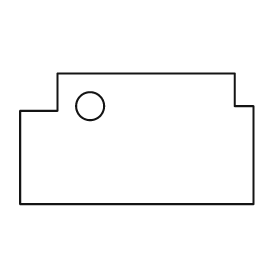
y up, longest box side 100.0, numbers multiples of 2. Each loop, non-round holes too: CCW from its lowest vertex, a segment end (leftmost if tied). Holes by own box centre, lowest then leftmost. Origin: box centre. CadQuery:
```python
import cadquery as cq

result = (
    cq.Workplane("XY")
    .moveTo(-50.0, -28.0)
    .lineTo(50.0, -28.0)
    .lineTo(50.0, 14.0)
    .lineTo(42.0, 14.0)
    .lineTo(42.0, 28.0)
    .lineTo(-34.0, 28.0)
    .lineTo(-34.0, 12.0)
    .lineTo(-50.0, 12.0)
    .close()
    .moveTo(-20.0, 14.0)
    .circle(6.0)
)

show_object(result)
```